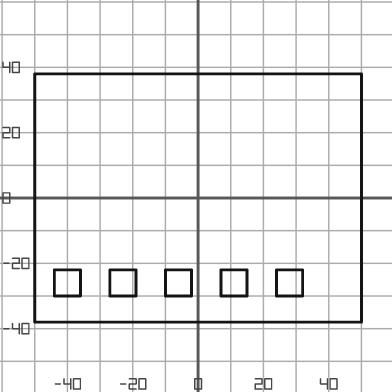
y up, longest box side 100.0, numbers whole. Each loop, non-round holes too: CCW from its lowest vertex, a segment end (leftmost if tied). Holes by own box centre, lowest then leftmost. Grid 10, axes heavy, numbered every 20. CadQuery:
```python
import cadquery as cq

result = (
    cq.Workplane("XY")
    .moveTo(-50.0, -38.0)
    .lineTo(50.0, -38.0)
    .lineTo(50.0, 38.0)
    .lineTo(-50.0, 38.0)
    .close()
    .moveTo(-44.0, -30.0)
    .lineTo(-36.0, -30.0)
    .lineTo(-36.0, -22.0)
    .lineTo(-44.0, -22.0)
    .close()
    .moveTo(-27.0, -30.0)
    .lineTo(-19.0, -30.0)
    .lineTo(-19.0, -22.0)
    .lineTo(-27.0, -22.0)
    .close()
    .moveTo(-10.0, -30.0)
    .lineTo(-2.0, -30.0)
    .lineTo(-2.0, -22.0)
    .lineTo(-10.0, -22.0)
    .close()
    .moveTo(7.0, -30.0)
    .lineTo(15.0, -30.0)
    .lineTo(15.0, -22.0)
    .lineTo(7.0, -22.0)
    .close()
    .moveTo(24.0, -30.0)
    .lineTo(32.0, -30.0)
    .lineTo(32.0, -22.0)
    .lineTo(24.0, -22.0)
    .close()
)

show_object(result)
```